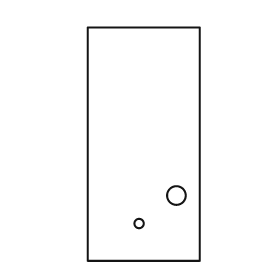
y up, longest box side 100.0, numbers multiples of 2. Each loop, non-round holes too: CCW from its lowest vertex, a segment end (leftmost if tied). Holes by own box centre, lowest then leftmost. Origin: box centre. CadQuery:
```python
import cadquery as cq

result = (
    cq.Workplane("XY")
    .moveTo(-24.0, -50.0)
    .lineTo(24.0, -50.0)
    .lineTo(24.0, 50.0)
    .lineTo(-24.0, 50.0)
    .close()
    .moveTo(-2.0, -34.0)
    .circle(2.0)
    .moveTo(14.0, -22.0)
    .circle(4.0)
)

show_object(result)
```